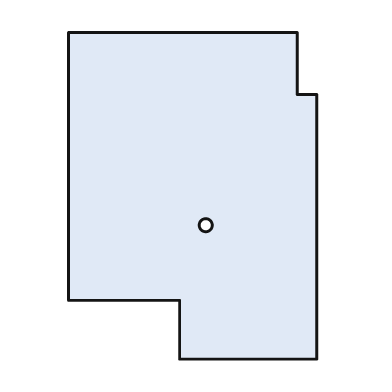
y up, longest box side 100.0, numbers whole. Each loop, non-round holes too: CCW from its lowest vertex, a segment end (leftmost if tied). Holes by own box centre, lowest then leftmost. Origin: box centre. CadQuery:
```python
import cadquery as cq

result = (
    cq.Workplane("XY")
    .moveTo(-4.0, -50.0)
    .lineTo(38.0, -50.0)
    .lineTo(38.0, 31.0)
    .lineTo(32.0, 31.0)
    .lineTo(32.0, 50.0)
    .lineTo(-38.0, 50.0)
    .lineTo(-38.0, -32.0)
    .lineTo(-4.0, -32.0)
    .close()
    .moveTo(4.0, -9.0)
    .circle(2.0)
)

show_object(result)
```